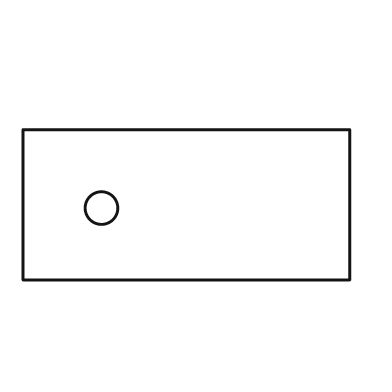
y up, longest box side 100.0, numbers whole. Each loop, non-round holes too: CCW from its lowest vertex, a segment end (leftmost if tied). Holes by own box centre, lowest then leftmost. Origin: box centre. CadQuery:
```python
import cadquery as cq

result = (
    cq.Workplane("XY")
    .moveTo(-50.0, -23.0)
    .lineTo(50.0, -23.0)
    .lineTo(50.0, 23.0)
    .lineTo(-50.0, 23.0)
    .close()
    .moveTo(-26.0, -1.0)
    .circle(5.0)
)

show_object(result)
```